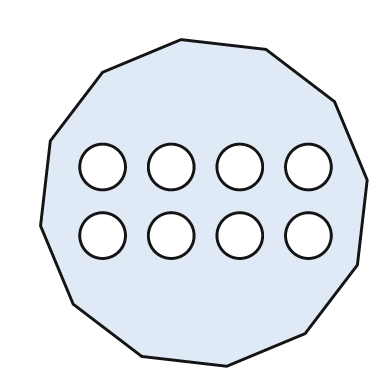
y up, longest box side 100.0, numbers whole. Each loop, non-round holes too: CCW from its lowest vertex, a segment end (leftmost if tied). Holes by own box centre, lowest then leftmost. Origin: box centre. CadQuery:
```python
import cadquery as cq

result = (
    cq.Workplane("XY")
    .moveTo(7.0, -50.0)
    .lineTo(31.0, -40.0)
    .lineTo(47.0, -19.0)
    .lineTo(50.0, 7.0)
    .lineTo(40.0, 31.0)
    .lineTo(19.0, 47.0)
    .lineTo(-7.0, 50.0)
    .lineTo(-31.0, 40.0)
    .lineTo(-47.0, 19.0)
    .lineTo(-50.0, -7.0)
    .lineTo(-40.0, -31.0)
    .lineTo(-19.0, -47.0)
    .close()
    .moveTo(-31.0, -10.0)
    .circle(7.0)
    .moveTo(-10.0, -10.0)
    .circle(7.0)
    .moveTo(11.0, -10.0)
    .circle(7.0)
    .moveTo(32.0, -10.0)
    .circle(7.0)
    .moveTo(-31.0, 11.0)
    .circle(7.0)
    .moveTo(-10.0, 11.0)
    .circle(7.0)
    .moveTo(11.0, 11.0)
    .circle(7.0)
    .moveTo(32.0, 11.0)
    .circle(7.0)
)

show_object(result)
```